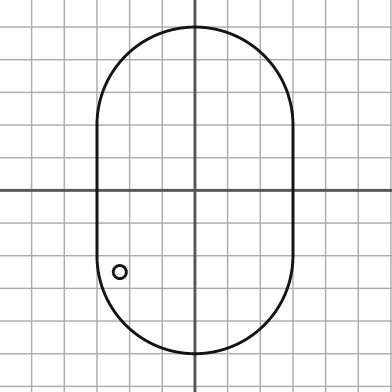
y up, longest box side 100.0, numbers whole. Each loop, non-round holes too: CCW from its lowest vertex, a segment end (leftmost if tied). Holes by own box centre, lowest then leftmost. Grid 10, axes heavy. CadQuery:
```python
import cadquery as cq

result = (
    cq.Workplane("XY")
    .moveTo(-30.0, -20.0)
    .threePointArc((0.0, -50.0), (30.0, -20.0))
    .lineTo(30.0, 20.0)
    .threePointArc((0.0, 50.0), (-30.0, 20.0))
    .close()
    .moveTo(-23.0, -25.0)
    .circle(2.0)
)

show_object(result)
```